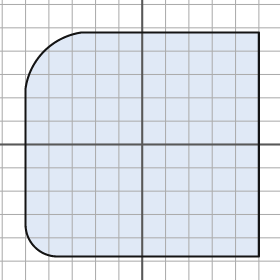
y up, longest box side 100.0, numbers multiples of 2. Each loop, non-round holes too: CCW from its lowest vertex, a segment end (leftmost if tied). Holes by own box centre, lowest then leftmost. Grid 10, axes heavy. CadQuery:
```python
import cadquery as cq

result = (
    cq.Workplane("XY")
    .moveTo(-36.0, -48.0)
    .lineTo(50.0, -48.0)
    .lineTo(50.0, 48.0)
    .lineTo(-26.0, 48.0)
    .threePointArc((-42.0, 40.0), (-50.0, 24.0))
    .lineTo(-50.0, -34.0)
    .threePointArc((-46.0, -44.0), (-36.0, -48.0))
    .close()
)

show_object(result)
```